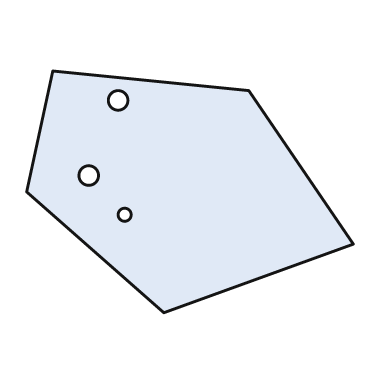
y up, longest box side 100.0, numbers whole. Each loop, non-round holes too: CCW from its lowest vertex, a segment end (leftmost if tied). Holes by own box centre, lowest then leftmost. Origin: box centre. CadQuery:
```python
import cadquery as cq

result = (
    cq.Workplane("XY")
    .moveTo(-8.0, -37.0)
    .lineTo(50.0, -16.0)
    .lineTo(18.0, 31.0)
    .lineTo(-42.0, 37.0)
    .lineTo(-50.0, 0.0)
    .close()
    .moveTo(-20.0, -7.0)
    .circle(2.0)
    .moveTo(-31.0, 5.0)
    .circle(3.0)
    .moveTo(-22.0, 28.0)
    .circle(3.0)
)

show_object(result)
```